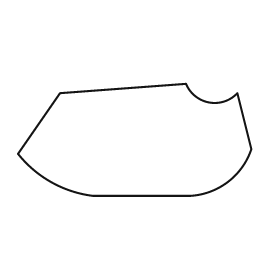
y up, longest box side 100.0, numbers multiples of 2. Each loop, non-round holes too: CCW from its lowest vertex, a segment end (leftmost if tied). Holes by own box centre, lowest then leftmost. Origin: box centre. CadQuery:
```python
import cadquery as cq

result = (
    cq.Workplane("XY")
    .moveTo(-18.0, -24.0)
    .lineTo(24.0, -24.0)
    .threePointArc((40.0, -18.0), (50.0, -4.0))
    .lineTo(44.0, 20.0)
    .threePointArc((32.0, 16.0), (22.0, 24.0))
    .lineTo(-32.0, 20.0)
    .lineTo(-50.0, -6.0)
    .threePointArc((-36.0, -18.0), (-18.0, -24.0))
    .close()
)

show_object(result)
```